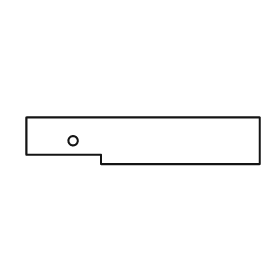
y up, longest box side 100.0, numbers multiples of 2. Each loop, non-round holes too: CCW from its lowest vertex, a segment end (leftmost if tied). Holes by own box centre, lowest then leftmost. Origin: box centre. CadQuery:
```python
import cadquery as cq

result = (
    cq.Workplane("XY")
    .moveTo(-18.0, -10.0)
    .lineTo(50.0, -10.0)
    .lineTo(50.0, 10.0)
    .lineTo(-50.0, 10.0)
    .lineTo(-50.0, -6.0)
    .lineTo(-18.0, -6.0)
    .close()
    .moveTo(-30.0, 0.0)
    .circle(2.0)
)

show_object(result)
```